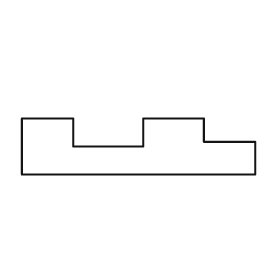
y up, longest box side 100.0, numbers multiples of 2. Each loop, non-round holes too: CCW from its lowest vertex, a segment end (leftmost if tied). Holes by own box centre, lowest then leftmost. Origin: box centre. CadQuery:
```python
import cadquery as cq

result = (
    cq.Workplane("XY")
    .moveTo(-50.0, -12.0)
    .lineTo(50.0, -12.0)
    .lineTo(50.0, 2.0)
    .lineTo(28.0, 2.0)
    .lineTo(28.0, 12.0)
    .lineTo(2.0, 12.0)
    .lineTo(2.0, 0.0)
    .lineTo(-28.0, 0.0)
    .lineTo(-28.0, 12.0)
    .lineTo(-50.0, 12.0)
    .close()
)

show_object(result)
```